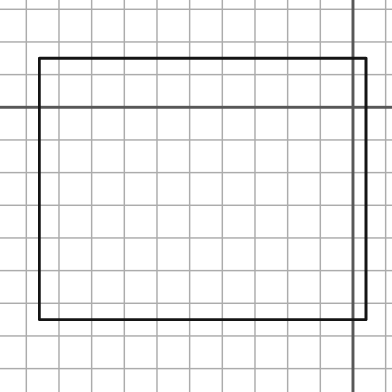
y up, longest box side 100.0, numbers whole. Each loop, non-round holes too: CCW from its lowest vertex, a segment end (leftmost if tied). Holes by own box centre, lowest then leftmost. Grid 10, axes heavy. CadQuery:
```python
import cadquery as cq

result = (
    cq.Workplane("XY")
    .moveTo(-96.0, -65.0)
    .lineTo(4.0, -65.0)
    .lineTo(4.0, 15.0)
    .lineTo(-96.0, 15.0)
    .close()
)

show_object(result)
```